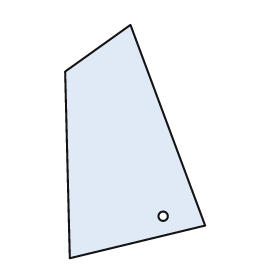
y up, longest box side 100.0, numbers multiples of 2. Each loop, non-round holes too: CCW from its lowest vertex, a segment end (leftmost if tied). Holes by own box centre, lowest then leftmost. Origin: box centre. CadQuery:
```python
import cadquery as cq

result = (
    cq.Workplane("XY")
    .moveTo(-28.0, -50.0)
    .lineTo(30.0, -36.0)
    .lineTo(-2.0, 50.0)
    .lineTo(-30.0, 30.0)
    .close()
    .moveTo(12.0, -32.0)
    .circle(2.0)
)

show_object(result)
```